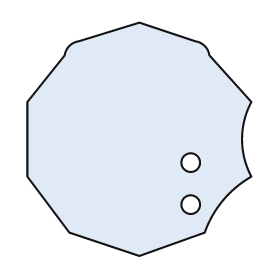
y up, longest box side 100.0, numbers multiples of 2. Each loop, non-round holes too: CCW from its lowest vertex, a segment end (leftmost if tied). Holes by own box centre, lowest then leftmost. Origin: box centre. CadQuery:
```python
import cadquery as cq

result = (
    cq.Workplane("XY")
    .moveTo(0.0, -50.0)
    .lineTo(28.0, -40.0)
    .threePointArc((36.0, -26.0), (48.0, -16.0))
    .threePointArc((44.0, 0.0), (48.0, 16.0))
    .lineTo(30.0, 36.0)
    .threePointArc((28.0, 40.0), (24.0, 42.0))
    .lineTo(0.0, 50.0)
    .lineTo(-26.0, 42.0)
    .threePointArc((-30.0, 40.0), (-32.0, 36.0))
    .lineTo(-48.0, 16.0)
    .lineTo(-48.0, -16.0)
    .lineTo(-30.0, -40.0)
    .close()
    .moveTo(22.0, -28.0)
    .circle(4.0)
    .moveTo(22.0, -10.0)
    .circle(4.0)
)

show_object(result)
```